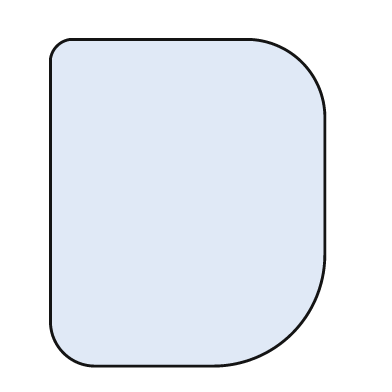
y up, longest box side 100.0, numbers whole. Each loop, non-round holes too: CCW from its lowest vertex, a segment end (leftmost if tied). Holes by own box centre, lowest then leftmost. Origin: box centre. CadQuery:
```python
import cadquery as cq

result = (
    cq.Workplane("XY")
    .moveTo(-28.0, -50.0)
    .lineTo(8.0, -50.0)
    .threePointArc((32.0, -40.0), (42.0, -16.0))
    .lineTo(42.0, 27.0)
    .threePointArc((35.0, 43.0), (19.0, 50.0))
    .lineTo(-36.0, 50.0)
    .threePointArc((-40.0, 48.0), (-42.0, 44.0))
    .lineTo(-42.0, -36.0)
    .threePointArc((-38.0, -46.0), (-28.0, -50.0))
    .close()
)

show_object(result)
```